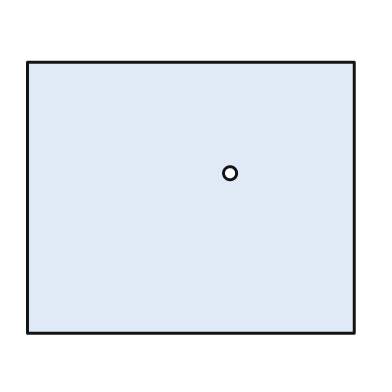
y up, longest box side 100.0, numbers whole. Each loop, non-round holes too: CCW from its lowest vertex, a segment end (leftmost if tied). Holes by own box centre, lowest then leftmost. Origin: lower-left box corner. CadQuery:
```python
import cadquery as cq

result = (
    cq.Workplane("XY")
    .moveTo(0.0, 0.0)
    .lineTo(100.0, 0.0)
    .lineTo(100.0, 83.0)
    .lineTo(0.0, 83.0)
    .close()
    .moveTo(62.0, 49.0)
    .circle(2.0)
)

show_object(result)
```